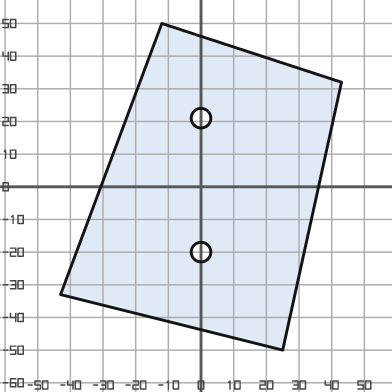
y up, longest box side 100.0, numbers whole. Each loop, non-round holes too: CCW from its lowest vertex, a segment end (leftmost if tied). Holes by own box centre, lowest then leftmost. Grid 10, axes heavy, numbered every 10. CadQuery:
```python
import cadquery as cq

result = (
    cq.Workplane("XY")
    .moveTo(25.0, -50.0)
    .lineTo(43.0, 32.0)
    .lineTo(-12.0, 50.0)
    .lineTo(-43.0, -33.0)
    .close()
    .moveTo(0.0, -20.0)
    .circle(3.0)
    .moveTo(0.0, 21.0)
    .circle(3.0)
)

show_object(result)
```